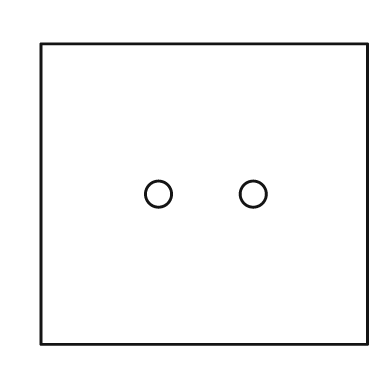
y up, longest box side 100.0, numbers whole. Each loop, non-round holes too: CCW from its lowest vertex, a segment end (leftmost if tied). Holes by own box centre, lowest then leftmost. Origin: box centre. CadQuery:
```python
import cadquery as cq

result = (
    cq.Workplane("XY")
    .moveTo(-50.0, -46.0)
    .lineTo(50.0, -46.0)
    .lineTo(50.0, 46.0)
    .lineTo(-50.0, 46.0)
    .close()
    .moveTo(-14.0, 0.0)
    .circle(4.0)
    .moveTo(15.0, 0.0)
    .circle(4.0)
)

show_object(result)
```